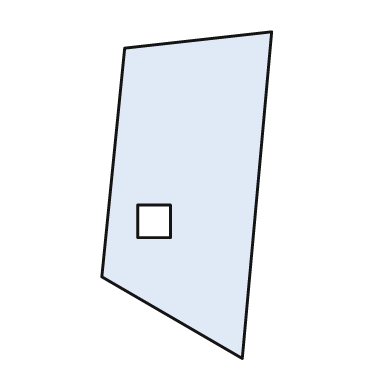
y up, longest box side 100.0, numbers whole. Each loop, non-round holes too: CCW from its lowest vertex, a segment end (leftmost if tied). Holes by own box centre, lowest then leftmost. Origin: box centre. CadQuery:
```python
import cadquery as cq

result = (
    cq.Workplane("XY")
    .moveTo(17.0, -50.0)
    .lineTo(26.0, 50.0)
    .lineTo(-19.0, 45.0)
    .lineTo(-26.0, -25.0)
    .close()
    .moveTo(-15.0, -13.0)
    .lineTo(-5.0, -13.0)
    .lineTo(-5.0, -3.0)
    .lineTo(-15.0, -3.0)
    .close()
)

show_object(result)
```